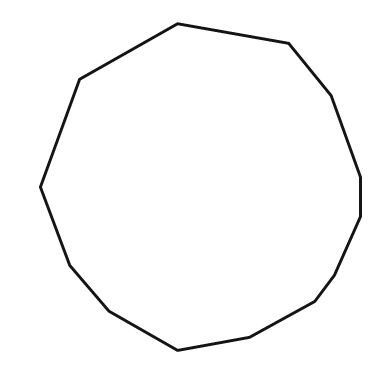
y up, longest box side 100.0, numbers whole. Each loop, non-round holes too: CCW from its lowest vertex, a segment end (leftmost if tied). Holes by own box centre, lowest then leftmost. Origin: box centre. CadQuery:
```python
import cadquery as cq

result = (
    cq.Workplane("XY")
    .moveTo(-7.0, -50.0)
    .lineTo(15.0, -46.0)
    .lineTo(35.0, -35.0)
    .lineTo(41.0, -27.0)
    .lineTo(49.0, -9.0)
    .lineTo(49.0, 3.0)
    .lineTo(40.0, 28.0)
    .lineTo(27.0, 44.0)
    .lineTo(-7.0, 50.0)
    .lineTo(-37.0, 33.0)
    .lineTo(-49.0, 0.0)
    .lineTo(-40.0, -24.0)
    .lineTo(-28.0, -38.0)
    .close()
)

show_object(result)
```